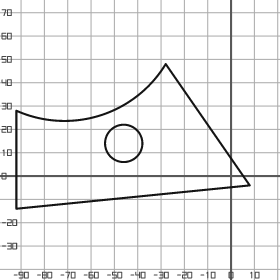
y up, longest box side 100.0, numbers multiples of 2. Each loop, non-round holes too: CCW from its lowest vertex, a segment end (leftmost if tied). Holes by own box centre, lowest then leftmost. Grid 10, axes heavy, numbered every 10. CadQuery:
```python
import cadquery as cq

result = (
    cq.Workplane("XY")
    .moveTo(-92.0, -14.0)
    .lineTo(8.0, -4.0)
    .lineTo(-28.0, 48.0)
    .threePointArc((-56.0, 26.0), (-92.0, 28.0))
    .close()
    .moveTo(-46.0, 14.0)
    .circle(8.0)
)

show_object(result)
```